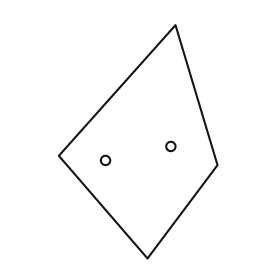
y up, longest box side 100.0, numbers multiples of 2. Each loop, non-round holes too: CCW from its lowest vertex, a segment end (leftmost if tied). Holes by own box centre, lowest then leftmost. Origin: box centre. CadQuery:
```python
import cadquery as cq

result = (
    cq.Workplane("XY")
    .moveTo(4.0, -50.0)
    .lineTo(34.0, -10.0)
    .lineTo(16.0, 50.0)
    .lineTo(-34.0, -6.0)
    .close()
    .moveTo(-14.0, -8.0)
    .circle(2.0)
    .moveTo(14.0, -2.0)
    .circle(2.0)
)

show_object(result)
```